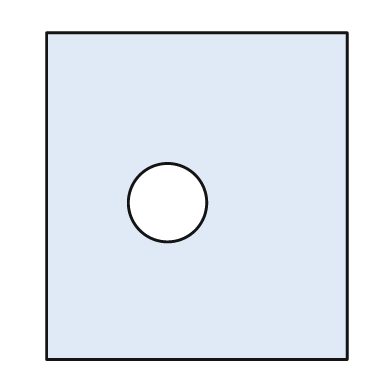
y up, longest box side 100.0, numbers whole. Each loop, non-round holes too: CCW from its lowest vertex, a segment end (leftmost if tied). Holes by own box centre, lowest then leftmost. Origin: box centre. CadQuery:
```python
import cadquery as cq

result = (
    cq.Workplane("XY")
    .moveTo(-46.0, -50.0)
    .lineTo(46.0, -50.0)
    .lineTo(46.0, 50.0)
    .lineTo(-46.0, 50.0)
    .close()
    .moveTo(-9.0, -2.0)
    .circle(12.0)
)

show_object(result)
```